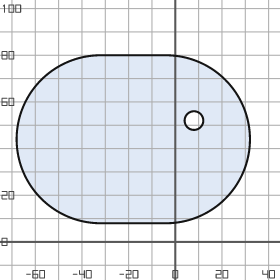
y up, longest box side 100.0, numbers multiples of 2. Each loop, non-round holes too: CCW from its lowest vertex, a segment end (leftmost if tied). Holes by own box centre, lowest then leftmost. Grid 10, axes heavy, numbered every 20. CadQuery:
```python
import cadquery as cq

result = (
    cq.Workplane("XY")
    .moveTo(-32.0, 8.0)
    .lineTo(-4.0, 8.0)
    .threePointArc((32.0, 44.0), (-4.0, 80.0))
    .lineTo(-32.0, 80.0)
    .threePointArc((-68.0, 44.0), (-32.0, 8.0))
    .close()
    .moveTo(8.0, 52.0)
    .circle(4.0)
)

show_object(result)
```